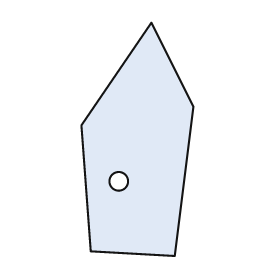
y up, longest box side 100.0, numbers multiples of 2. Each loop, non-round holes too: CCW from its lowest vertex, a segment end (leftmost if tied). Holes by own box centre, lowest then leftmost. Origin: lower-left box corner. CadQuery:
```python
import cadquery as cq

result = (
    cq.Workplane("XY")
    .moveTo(40.0, 0.0)
    .lineTo(48.0, 64.0)
    .lineTo(30.0, 100.0)
    .lineTo(0.0, 56.0)
    .lineTo(4.0, 2.0)
    .close()
    .moveTo(16.0, 32.0)
    .circle(4.0)
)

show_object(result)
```